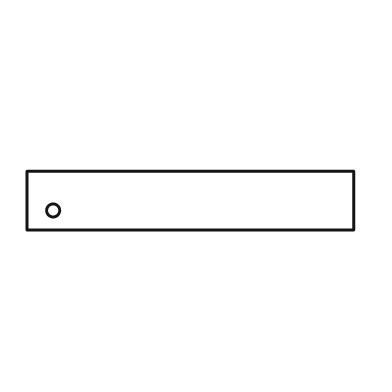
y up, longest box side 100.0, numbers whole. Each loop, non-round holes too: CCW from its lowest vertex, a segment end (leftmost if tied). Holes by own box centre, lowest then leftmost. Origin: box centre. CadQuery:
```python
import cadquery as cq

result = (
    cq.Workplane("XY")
    .moveTo(-50.0, -9.0)
    .lineTo(50.0, -9.0)
    .lineTo(50.0, 9.0)
    .lineTo(-50.0, 9.0)
    .close()
    .moveTo(-42.0, -3.0)
    .circle(2.0)
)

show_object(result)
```